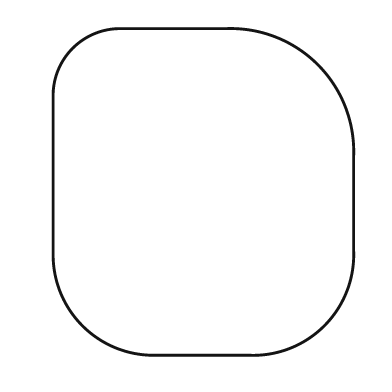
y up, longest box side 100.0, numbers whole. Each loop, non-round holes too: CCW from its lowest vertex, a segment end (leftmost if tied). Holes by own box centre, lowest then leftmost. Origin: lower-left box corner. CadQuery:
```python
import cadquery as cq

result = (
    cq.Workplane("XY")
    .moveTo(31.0, 0.0)
    .lineTo(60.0, 0.0)
    .threePointArc((83.0, 9.0), (92.0, 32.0))
    .lineTo(92.0, 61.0)
    .threePointArc((81.0, 89.0), (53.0, 100.0))
    .lineTo(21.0, 100.0)
    .threePointArc((6.0, 94.0), (0.0, 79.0))
    .lineTo(0.0, 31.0)
    .threePointArc((9.0, 9.0), (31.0, 0.0))
    .close()
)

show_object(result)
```